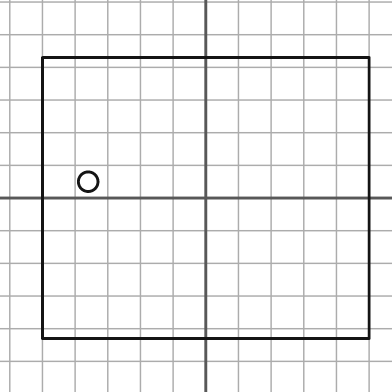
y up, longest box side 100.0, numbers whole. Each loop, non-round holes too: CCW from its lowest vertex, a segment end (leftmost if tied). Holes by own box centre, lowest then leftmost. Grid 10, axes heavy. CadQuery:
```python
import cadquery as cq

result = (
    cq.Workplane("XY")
    .moveTo(-50.0, -43.0)
    .lineTo(50.0, -43.0)
    .lineTo(50.0, 43.0)
    .lineTo(-50.0, 43.0)
    .close()
    .moveTo(-36.0, 5.0)
    .circle(3.0)
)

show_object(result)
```